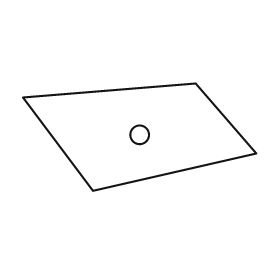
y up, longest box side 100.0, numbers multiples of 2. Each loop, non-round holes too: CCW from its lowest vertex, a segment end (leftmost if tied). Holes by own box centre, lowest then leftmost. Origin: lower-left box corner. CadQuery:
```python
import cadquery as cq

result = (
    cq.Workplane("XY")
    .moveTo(30.0, 0.0)
    .lineTo(100.0, 16.0)
    .lineTo(74.0, 46.0)
    .lineTo(0.0, 40.0)
    .close()
    .moveTo(50.0, 24.0)
    .circle(4.0)
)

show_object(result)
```